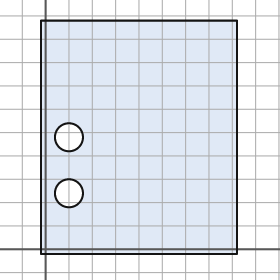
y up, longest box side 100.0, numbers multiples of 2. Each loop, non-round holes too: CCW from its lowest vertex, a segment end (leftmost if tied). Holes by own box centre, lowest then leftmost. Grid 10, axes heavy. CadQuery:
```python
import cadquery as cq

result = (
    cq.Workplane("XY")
    .moveTo(-2.0, -2.0)
    .lineTo(82.0, -2.0)
    .lineTo(82.0, 98.0)
    .lineTo(-2.0, 98.0)
    .close()
    .moveTo(10.0, 24.0)
    .circle(6.0)
    .moveTo(10.0, 48.0)
    .circle(6.0)
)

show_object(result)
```